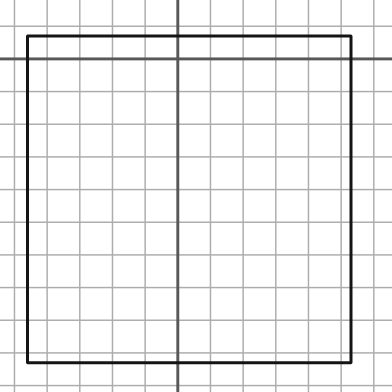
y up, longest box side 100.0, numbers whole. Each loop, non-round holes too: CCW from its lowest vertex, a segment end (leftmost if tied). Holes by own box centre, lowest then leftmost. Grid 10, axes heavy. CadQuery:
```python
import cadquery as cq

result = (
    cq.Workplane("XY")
    .moveTo(-46.0, -93.0)
    .lineTo(53.0, -93.0)
    .lineTo(53.0, 7.0)
    .lineTo(-46.0, 7.0)
    .close()
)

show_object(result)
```